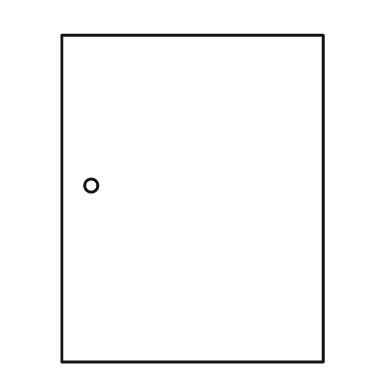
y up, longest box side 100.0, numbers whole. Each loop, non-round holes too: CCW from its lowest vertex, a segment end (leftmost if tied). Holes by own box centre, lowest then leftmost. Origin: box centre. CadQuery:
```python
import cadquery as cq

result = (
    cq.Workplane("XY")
    .moveTo(-40.0, -50.0)
    .lineTo(40.0, -50.0)
    .lineTo(40.0, 50.0)
    .lineTo(-40.0, 50.0)
    .close()
    .moveTo(-31.0, 4.0)
    .circle(2.0)
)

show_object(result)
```